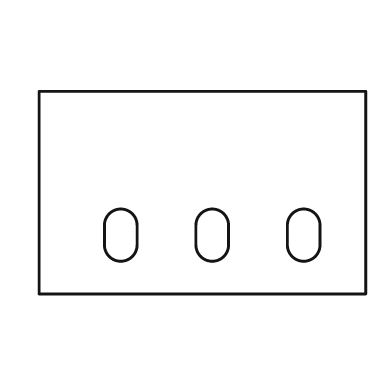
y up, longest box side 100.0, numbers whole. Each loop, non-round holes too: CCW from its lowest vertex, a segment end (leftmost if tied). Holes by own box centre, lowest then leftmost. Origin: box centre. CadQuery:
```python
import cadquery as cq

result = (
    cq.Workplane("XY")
    .moveTo(-50.0, -31.0)
    .lineTo(50.0, -31.0)
    .lineTo(50.0, 31.0)
    .lineTo(-50.0, 31.0)
    .close()
    .moveTo(-30.0, -16.0)
    .threePointArc((-25.0, -21.0), (-20.0, -16.0))
    .lineTo(-20.0, -10.0)
    .threePointArc((-25.0, -5.0), (-30.0, -10.0))
    .close()
    .moveTo(-2.0, -16.0)
    .threePointArc((3.0, -21.0), (8.0, -16.0))
    .lineTo(8.0, -10.0)
    .threePointArc((3.0, -5.0), (-2.0, -10.0))
    .close()
    .moveTo(26.0, -16.0)
    .threePointArc((31.0, -21.0), (36.0, -16.0))
    .lineTo(36.0, -10.0)
    .threePointArc((31.0, -5.0), (26.0, -10.0))
    .close()
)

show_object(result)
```